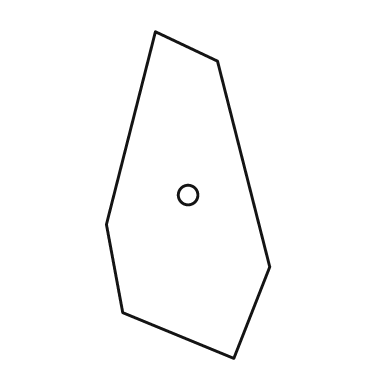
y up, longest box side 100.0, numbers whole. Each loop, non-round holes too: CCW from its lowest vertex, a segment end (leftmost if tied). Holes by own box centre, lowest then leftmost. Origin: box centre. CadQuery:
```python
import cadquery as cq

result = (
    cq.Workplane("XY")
    .moveTo(14.0, -50.0)
    .lineTo(25.0, -22.0)
    .lineTo(9.0, 41.0)
    .lineTo(-10.0, 50.0)
    .lineTo(-25.0, -9.0)
    .lineTo(-20.0, -36.0)
    .close()
    .moveTo(0.0, 0.0)
    .circle(3.0)
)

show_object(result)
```